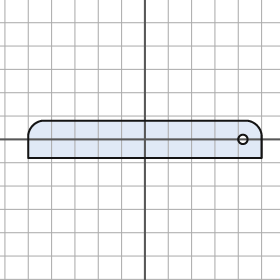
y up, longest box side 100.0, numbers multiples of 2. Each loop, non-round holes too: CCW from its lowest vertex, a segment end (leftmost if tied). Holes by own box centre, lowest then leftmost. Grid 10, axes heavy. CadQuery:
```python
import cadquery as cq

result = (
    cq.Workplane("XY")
    .moveTo(-50.0, -8.0)
    .lineTo(50.0, -8.0)
    .lineTo(50.0, 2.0)
    .threePointArc((48.0, 6.0), (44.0, 8.0))
    .lineTo(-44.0, 8.0)
    .threePointArc((-48.0, 6.0), (-50.0, 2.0))
    .close()
    .moveTo(42.0, 0.0)
    .circle(2.0)
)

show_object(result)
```